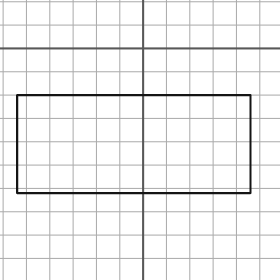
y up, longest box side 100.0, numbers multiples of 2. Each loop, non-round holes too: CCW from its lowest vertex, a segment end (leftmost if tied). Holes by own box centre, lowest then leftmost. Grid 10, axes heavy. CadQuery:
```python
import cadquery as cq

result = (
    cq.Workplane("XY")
    .moveTo(-54.0, -62.0)
    .lineTo(46.0, -62.0)
    .lineTo(46.0, -20.0)
    .lineTo(-54.0, -20.0)
    .close()
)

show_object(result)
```